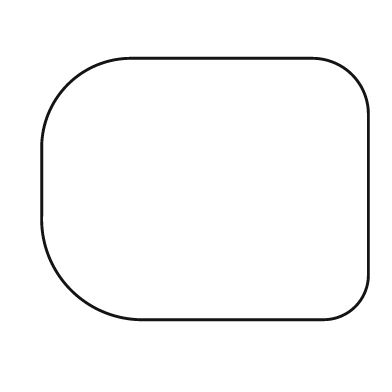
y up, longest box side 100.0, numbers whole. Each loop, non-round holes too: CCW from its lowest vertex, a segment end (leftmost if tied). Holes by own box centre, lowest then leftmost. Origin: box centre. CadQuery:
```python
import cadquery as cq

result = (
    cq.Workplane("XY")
    .moveTo(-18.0, -40.0)
    .lineTo(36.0, -40.0)
    .threePointArc((46.0, -36.0), (50.0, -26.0))
    .lineTo(50.0, 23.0)
    .threePointArc((45.0, 35.0), (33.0, 40.0))
    .lineTo(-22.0, 40.0)
    .threePointArc((-42.0, 32.0), (-50.0, 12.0))
    .lineTo(-50.0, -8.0)
    .threePointArc((-41.0, -31.0), (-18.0, -40.0))
    .close()
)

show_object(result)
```